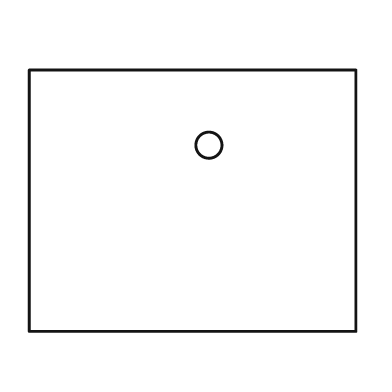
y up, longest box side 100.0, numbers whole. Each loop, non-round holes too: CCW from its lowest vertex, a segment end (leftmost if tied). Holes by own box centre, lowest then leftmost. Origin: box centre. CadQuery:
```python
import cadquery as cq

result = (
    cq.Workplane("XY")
    .moveTo(-50.0, -40.0)
    .lineTo(50.0, -40.0)
    .lineTo(50.0, 40.0)
    .lineTo(-50.0, 40.0)
    .close()
    .moveTo(5.0, 17.0)
    .circle(4.0)
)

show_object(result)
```